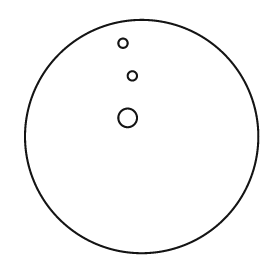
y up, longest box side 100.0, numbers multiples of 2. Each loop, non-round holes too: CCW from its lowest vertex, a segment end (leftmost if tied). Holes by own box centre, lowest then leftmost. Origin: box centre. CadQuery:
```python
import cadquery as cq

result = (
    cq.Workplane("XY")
    .moveTo(0.0, 0.0)
    .circle(50.0)
    .moveTo(-6.0, 8.0)
    .circle(4.0)
    .moveTo(-4.0, 26.0)
    .circle(2.0)
    .moveTo(-8.0, 40.0)
    .circle(2.0)
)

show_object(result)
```